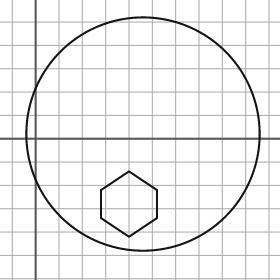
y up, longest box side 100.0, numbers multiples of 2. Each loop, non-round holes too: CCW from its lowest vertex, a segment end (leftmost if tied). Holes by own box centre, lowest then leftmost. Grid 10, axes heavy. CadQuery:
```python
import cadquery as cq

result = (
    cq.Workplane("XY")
    .moveTo(46.0, 2.0)
    .circle(50.0)
    .moveTo(40.0, -42.0)
    .lineTo(52.0, -34.0)
    .lineTo(52.0, -22.0)
    .lineTo(40.0, -14.0)
    .lineTo(28.0, -22.0)
    .lineTo(28.0, -34.0)
    .close()
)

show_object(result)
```